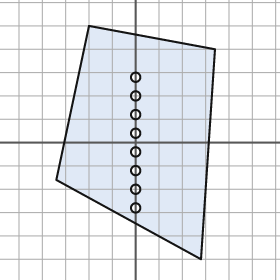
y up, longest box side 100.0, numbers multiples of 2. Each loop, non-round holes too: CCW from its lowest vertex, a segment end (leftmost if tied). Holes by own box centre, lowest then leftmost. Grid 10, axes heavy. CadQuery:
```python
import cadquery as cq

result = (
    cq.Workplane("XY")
    .moveTo(28.0, -50.0)
    .lineTo(34.0, 40.0)
    .lineTo(-20.0, 50.0)
    .lineTo(-34.0, -16.0)
    .close()
    .moveTo(0.0, -28.0)
    .circle(2.0)
    .moveTo(0.0, -20.0)
    .circle(2.0)
    .moveTo(0.0, -12.0)
    .circle(2.0)
    .moveTo(0.0, -4.0)
    .circle(2.0)
    .moveTo(0.0, 4.0)
    .circle(2.0)
    .moveTo(0.0, 12.0)
    .circle(2.0)
    .moveTo(0.0, 20.0)
    .circle(2.0)
    .moveTo(0.0, 28.0)
    .circle(2.0)
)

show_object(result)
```